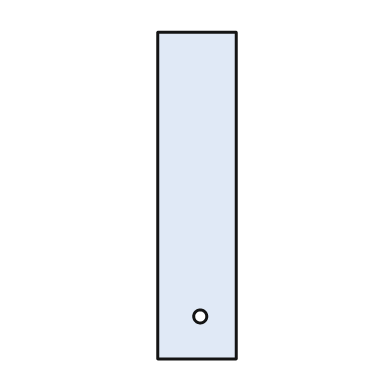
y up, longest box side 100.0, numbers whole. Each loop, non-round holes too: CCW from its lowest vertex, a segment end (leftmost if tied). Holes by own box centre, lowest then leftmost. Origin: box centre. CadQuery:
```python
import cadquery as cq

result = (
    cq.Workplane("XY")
    .moveTo(-12.0, -50.0)
    .lineTo(12.0, -50.0)
    .lineTo(12.0, 50.0)
    .lineTo(-12.0, 50.0)
    .close()
    .moveTo(1.0, -37.0)
    .circle(2.0)
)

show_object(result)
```